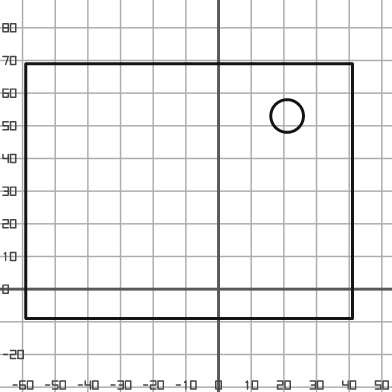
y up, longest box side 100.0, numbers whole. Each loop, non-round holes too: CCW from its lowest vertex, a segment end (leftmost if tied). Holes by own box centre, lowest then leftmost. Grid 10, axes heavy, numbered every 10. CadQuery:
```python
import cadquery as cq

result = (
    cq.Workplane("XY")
    .moveTo(-59.0, -9.0)
    .lineTo(41.0, -9.0)
    .lineTo(41.0, 69.0)
    .lineTo(-59.0, 69.0)
    .close()
    .moveTo(21.0, 53.0)
    .circle(5.0)
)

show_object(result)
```